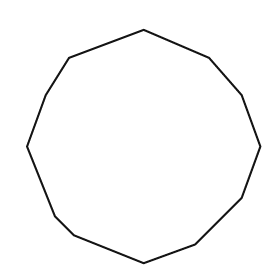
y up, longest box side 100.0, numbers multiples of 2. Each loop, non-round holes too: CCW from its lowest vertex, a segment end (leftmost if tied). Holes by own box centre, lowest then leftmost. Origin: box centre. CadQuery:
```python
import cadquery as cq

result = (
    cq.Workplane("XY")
    .moveTo(0.0, -50.0)
    .lineTo(22.0, -42.0)
    .lineTo(42.0, -22.0)
    .lineTo(50.0, 0.0)
    .lineTo(42.0, 22.0)
    .lineTo(28.0, 38.0)
    .lineTo(0.0, 50.0)
    .lineTo(-32.0, 38.0)
    .lineTo(-42.0, 22.0)
    .lineTo(-50.0, 0.0)
    .lineTo(-38.0, -30.0)
    .lineTo(-30.0, -38.0)
    .close()
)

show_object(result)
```